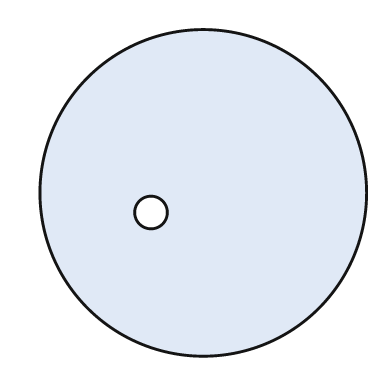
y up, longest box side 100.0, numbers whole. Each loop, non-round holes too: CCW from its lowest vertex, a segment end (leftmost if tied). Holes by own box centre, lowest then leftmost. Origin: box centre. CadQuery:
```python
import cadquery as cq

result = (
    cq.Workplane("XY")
    .moveTo(0.0, 0.0)
    .circle(50.0)
    .moveTo(-16.0, -6.0)
    .circle(5.0)
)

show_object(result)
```